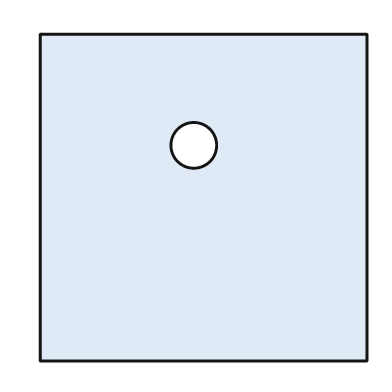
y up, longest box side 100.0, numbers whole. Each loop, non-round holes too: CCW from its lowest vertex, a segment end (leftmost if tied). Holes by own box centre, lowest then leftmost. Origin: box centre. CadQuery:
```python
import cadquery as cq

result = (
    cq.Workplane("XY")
    .moveTo(-50.0, -50.0)
    .lineTo(50.0, -50.0)
    .lineTo(50.0, 50.0)
    .lineTo(-50.0, 50.0)
    .close()
    .moveTo(-3.0, 16.0)
    .circle(7.0)
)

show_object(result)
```